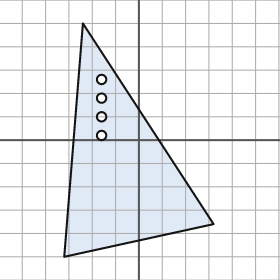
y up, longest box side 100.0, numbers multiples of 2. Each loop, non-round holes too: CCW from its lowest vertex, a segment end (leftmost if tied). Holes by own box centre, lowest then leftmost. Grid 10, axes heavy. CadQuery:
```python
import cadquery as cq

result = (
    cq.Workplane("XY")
    .moveTo(-32.0, -50.0)
    .lineTo(32.0, -36.0)
    .lineTo(-24.0, 50.0)
    .close()
    .moveTo(-16.0, 2.0)
    .circle(2.0)
    .moveTo(-16.0, 10.0)
    .circle(2.0)
    .moveTo(-16.0, 18.0)
    .circle(2.0)
    .moveTo(-16.0, 26.0)
    .circle(2.0)
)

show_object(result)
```